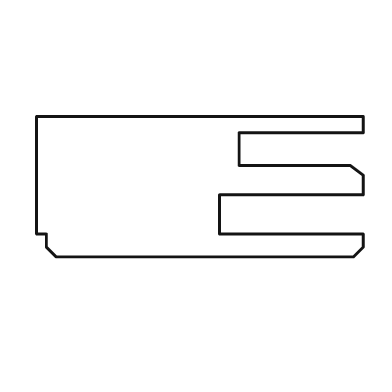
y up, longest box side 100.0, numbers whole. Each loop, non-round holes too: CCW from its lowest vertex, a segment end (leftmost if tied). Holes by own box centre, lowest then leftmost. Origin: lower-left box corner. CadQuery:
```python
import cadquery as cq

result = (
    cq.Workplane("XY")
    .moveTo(6.0, 0.0)
    .lineTo(97.0, 0.0)
    .lineTo(100.0, 3.0)
    .lineTo(100.0, 7.0)
    .lineTo(56.0, 7.0)
    .lineTo(56.0, 19.0)
    .lineTo(100.0, 19.0)
    .lineTo(100.0, 25.0)
    .lineTo(96.0, 28.0)
    .lineTo(62.0, 28.0)
    .lineTo(62.0, 38.0)
    .lineTo(100.0, 38.0)
    .lineTo(100.0, 43.0)
    .lineTo(0.0, 43.0)
    .lineTo(0.0, 7.0)
    .lineTo(3.0, 7.0)
    .lineTo(3.0, 3.0)
    .close()
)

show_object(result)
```